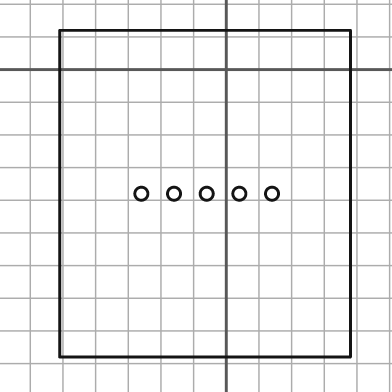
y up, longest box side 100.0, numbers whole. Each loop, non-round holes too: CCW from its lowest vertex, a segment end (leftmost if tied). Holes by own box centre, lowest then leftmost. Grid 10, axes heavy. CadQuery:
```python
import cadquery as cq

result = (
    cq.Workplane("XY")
    .moveTo(-51.0, -88.0)
    .lineTo(38.0, -88.0)
    .lineTo(38.0, 12.0)
    .lineTo(-51.0, 12.0)
    .close()
    .moveTo(-26.0, -38.0)
    .circle(2.0)
    .moveTo(-16.0, -38.0)
    .circle(2.0)
    .moveTo(-6.0, -38.0)
    .circle(2.0)
    .moveTo(4.0, -38.0)
    .circle(2.0)
    .moveTo(14.0, -38.0)
    .circle(2.0)
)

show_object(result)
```